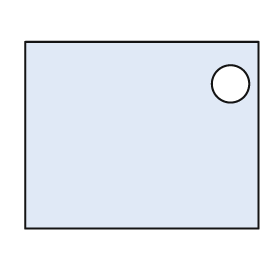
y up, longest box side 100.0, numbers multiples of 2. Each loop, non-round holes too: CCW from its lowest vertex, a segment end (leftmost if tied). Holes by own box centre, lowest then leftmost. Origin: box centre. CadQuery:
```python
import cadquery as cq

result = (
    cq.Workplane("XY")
    .moveTo(-50.0, -40.0)
    .lineTo(50.0, -40.0)
    .lineTo(50.0, 40.0)
    .lineTo(-50.0, 40.0)
    .close()
    .moveTo(38.0, 22.0)
    .circle(8.0)
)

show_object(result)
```